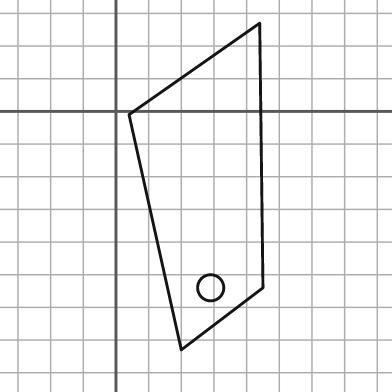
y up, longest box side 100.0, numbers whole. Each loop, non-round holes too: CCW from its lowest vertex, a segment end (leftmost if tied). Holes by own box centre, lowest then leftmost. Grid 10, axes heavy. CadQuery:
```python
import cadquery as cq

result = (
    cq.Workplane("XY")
    .moveTo(20.0, -73.0)
    .lineTo(45.0, -54.0)
    .lineTo(44.0, 27.0)
    .lineTo(4.0, -1.0)
    .close()
    .moveTo(29.0, -54.0)
    .circle(4.0)
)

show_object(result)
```